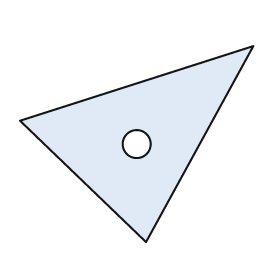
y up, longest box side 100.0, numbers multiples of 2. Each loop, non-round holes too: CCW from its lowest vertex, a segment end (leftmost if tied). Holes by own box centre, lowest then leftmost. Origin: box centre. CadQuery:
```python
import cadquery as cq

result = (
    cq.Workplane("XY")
    .moveTo(4.0, -42.0)
    .lineTo(50.0, 42.0)
    .lineTo(-50.0, 10.0)
    .close()
    .moveTo(0.0, 0.0)
    .circle(6.0)
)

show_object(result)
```